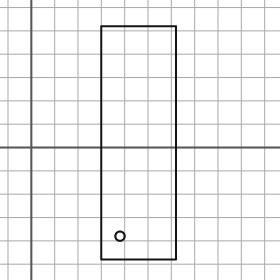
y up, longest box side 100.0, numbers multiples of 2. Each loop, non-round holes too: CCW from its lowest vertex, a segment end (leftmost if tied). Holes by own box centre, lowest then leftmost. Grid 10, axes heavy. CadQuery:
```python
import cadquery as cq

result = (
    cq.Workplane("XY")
    .moveTo(30.0, -48.0)
    .lineTo(62.0, -48.0)
    .lineTo(62.0, 52.0)
    .lineTo(30.0, 52.0)
    .close()
    .moveTo(38.0, -38.0)
    .circle(2.0)
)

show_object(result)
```